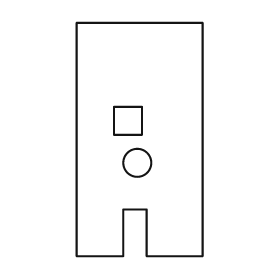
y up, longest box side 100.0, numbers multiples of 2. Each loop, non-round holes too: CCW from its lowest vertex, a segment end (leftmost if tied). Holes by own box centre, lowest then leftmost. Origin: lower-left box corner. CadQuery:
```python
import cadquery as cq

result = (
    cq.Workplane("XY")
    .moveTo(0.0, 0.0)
    .lineTo(20.0, 0.0)
    .lineTo(20.0, 20.0)
    .lineTo(30.0, 20.0)
    .lineTo(30.0, 0.0)
    .lineTo(54.0, 0.0)
    .lineTo(54.0, 100.0)
    .lineTo(0.0, 100.0)
    .close()
    .moveTo(26.0, 40.0)
    .circle(6.0)
    .moveTo(16.0, 52.0)
    .lineTo(28.0, 52.0)
    .lineTo(28.0, 64.0)
    .lineTo(16.0, 64.0)
    .close()
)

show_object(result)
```